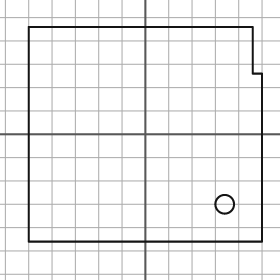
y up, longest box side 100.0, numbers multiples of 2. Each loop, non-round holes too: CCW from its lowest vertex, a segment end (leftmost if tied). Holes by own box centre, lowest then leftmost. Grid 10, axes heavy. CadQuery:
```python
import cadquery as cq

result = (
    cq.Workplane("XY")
    .moveTo(-50.0, -46.0)
    .lineTo(50.0, -46.0)
    .lineTo(50.0, 26.0)
    .lineTo(46.0, 26.0)
    .lineTo(46.0, 46.0)
    .lineTo(-50.0, 46.0)
    .close()
    .moveTo(34.0, -30.0)
    .circle(4.0)
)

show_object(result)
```